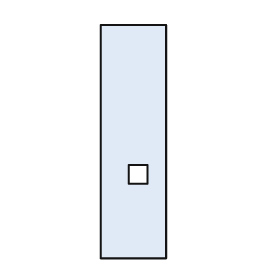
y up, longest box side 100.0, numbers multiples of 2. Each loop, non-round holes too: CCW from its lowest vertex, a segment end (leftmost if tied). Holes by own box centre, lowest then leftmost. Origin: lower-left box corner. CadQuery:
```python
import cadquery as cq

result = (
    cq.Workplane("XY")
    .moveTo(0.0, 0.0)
    .lineTo(28.0, 0.0)
    .lineTo(28.0, 100.0)
    .lineTo(0.0, 100.0)
    .close()
    .moveTo(12.0, 32.0)
    .lineTo(20.0, 32.0)
    .lineTo(20.0, 40.0)
    .lineTo(12.0, 40.0)
    .close()
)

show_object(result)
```